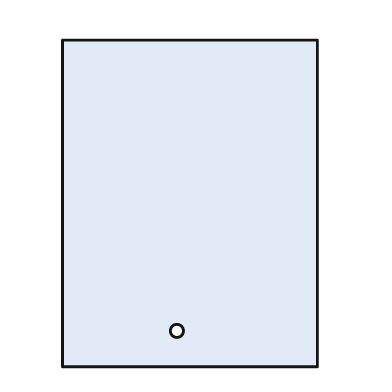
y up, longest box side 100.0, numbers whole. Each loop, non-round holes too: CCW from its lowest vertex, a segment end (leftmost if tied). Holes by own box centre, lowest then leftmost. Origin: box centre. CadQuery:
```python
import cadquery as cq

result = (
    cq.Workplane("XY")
    .moveTo(-39.0, -50.0)
    .lineTo(39.0, -50.0)
    .lineTo(39.0, 50.0)
    .lineTo(-39.0, 50.0)
    .close()
    .moveTo(-4.0, -39.0)
    .circle(2.0)
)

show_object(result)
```